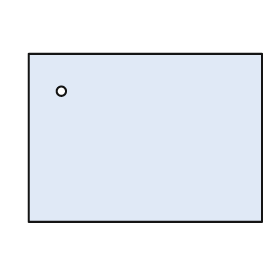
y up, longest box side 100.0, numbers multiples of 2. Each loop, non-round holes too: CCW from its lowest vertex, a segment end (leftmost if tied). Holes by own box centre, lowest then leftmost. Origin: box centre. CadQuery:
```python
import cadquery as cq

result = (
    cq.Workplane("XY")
    .moveTo(-50.0, -36.0)
    .lineTo(50.0, -36.0)
    .lineTo(50.0, 36.0)
    .lineTo(-50.0, 36.0)
    .close()
    .moveTo(-36.0, 20.0)
    .circle(2.0)
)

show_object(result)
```